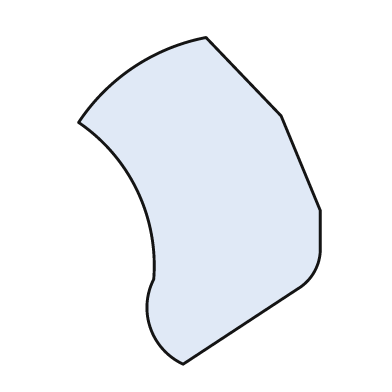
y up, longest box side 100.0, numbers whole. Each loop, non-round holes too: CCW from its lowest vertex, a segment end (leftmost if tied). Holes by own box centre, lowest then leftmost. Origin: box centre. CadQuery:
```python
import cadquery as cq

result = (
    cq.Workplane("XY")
    .moveTo(-5.0, -50.0)
    .lineTo(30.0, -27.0)
    .threePointArc((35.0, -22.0), (37.0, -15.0))
    .lineTo(37.0, -3.0)
    .lineTo(25.0, 26.0)
    .lineTo(2.0, 50.0)
    .threePointArc((-20.0, 41.0), (-37.0, 24.0))
    .threePointArc((-19.0, 3.0), (-14.0, -24.0))
    .threePointArc((-15.0, -39.0), (-5.0, -50.0))
    .close()
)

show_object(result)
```